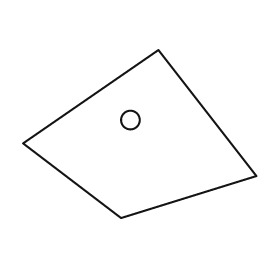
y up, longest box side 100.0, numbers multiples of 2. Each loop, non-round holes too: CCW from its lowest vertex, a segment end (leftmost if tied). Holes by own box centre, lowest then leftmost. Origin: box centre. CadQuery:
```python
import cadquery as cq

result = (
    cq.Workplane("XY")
    .moveTo(-8.0, -36.0)
    .lineTo(50.0, -18.0)
    .lineTo(8.0, 36.0)
    .lineTo(-50.0, -4.0)
    .close()
    .moveTo(-4.0, 6.0)
    .circle(4.0)
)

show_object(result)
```